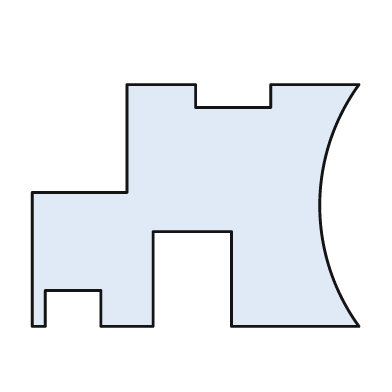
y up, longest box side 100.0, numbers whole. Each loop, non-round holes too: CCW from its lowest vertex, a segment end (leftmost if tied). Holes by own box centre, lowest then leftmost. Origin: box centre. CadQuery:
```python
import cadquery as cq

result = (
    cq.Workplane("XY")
    .moveTo(-50.0, -37.0)
    .lineTo(-46.0, -37.0)
    .lineTo(-46.0, -26.0)
    .lineTo(-29.0, -26.0)
    .lineTo(-29.0, -37.0)
    .lineTo(-13.0, -37.0)
    .lineTo(-13.0, -8.0)
    .lineTo(11.0, -8.0)
    .lineTo(11.0, -37.0)
    .lineTo(50.0, -37.0)
    .threePointArc((38.0, 0.0), (50.0, 37.0))
    .lineTo(23.0, 37.0)
    .lineTo(23.0, 30.0)
    .lineTo(0.0, 30.0)
    .lineTo(0.0, 37.0)
    .lineTo(-21.0, 37.0)
    .lineTo(-21.0, 4.0)
    .lineTo(-50.0, 4.0)
    .close()
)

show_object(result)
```